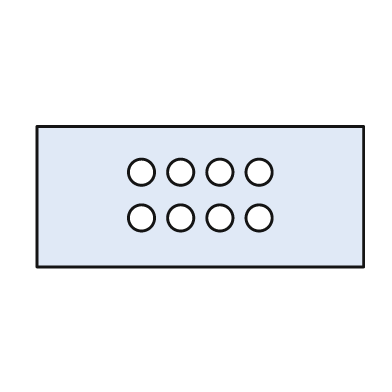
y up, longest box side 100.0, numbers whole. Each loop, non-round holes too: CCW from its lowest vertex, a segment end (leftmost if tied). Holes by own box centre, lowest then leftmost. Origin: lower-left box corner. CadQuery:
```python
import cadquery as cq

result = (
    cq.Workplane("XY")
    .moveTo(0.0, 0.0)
    .lineTo(100.0, 0.0)
    .lineTo(100.0, 43.0)
    .lineTo(0.0, 43.0)
    .close()
    .moveTo(32.0, 15.0)
    .circle(4.0)
    .moveTo(44.0, 15.0)
    .circle(4.0)
    .moveTo(56.0, 15.0)
    .circle(4.0)
    .moveTo(68.0, 15.0)
    .circle(4.0)
    .moveTo(32.0, 29.0)
    .circle(4.0)
    .moveTo(44.0, 29.0)
    .circle(4.0)
    .moveTo(56.0, 29.0)
    .circle(4.0)
    .moveTo(68.0, 29.0)
    .circle(4.0)
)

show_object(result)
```